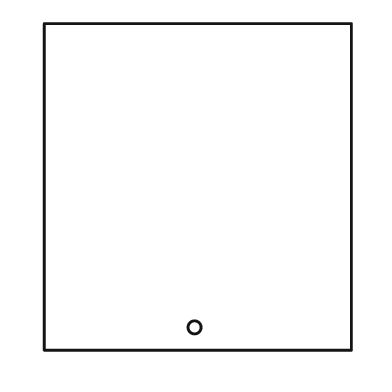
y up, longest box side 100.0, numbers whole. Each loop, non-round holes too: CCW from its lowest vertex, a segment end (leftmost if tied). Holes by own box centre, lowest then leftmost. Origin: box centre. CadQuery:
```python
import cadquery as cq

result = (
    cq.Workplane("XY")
    .moveTo(-47.0, -50.0)
    .lineTo(47.0, -50.0)
    .lineTo(47.0, 50.0)
    .lineTo(-47.0, 50.0)
    .close()
    .moveTo(-1.0, -43.0)
    .circle(2.0)
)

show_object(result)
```